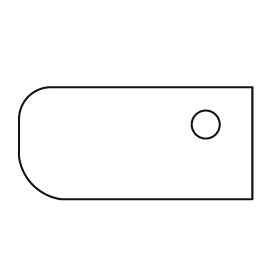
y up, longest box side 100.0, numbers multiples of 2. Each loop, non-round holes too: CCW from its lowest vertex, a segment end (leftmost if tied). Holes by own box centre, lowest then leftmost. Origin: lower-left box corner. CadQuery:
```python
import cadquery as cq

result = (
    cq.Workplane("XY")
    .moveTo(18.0, 0.0)
    .lineTo(100.0, 0.0)
    .lineTo(100.0, 48.0)
    .lineTo(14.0, 48.0)
    .threePointArc((4.0, 44.0), (0.0, 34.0))
    .lineTo(0.0, 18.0)
    .threePointArc((6.0, 6.0), (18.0, 0.0))
    .close()
    .moveTo(80.0, 32.0)
    .circle(6.0)
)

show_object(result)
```